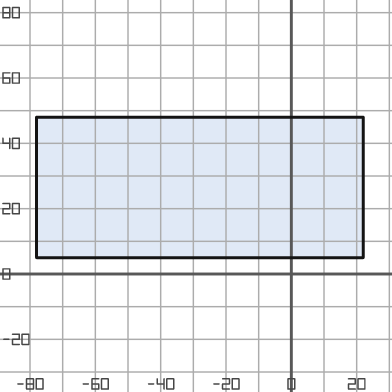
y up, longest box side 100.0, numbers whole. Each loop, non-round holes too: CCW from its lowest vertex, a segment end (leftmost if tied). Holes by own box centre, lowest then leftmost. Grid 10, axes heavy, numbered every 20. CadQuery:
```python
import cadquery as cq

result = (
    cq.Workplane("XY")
    .moveTo(-78.0, 5.0)
    .lineTo(22.0, 5.0)
    .lineTo(22.0, 48.0)
    .lineTo(-78.0, 48.0)
    .close()
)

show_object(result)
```